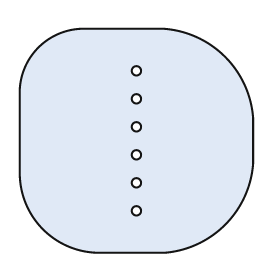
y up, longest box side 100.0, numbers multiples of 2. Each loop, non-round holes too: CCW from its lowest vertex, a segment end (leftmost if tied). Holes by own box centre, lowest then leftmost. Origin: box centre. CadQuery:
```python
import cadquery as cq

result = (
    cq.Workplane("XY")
    .moveTo(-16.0, -48.0)
    .lineTo(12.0, -48.0)
    .threePointArc((38.0, -36.0), (50.0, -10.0))
    .lineTo(50.0, 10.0)
    .threePointArc((38.0, 36.0), (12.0, 48.0))
    .lineTo(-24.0, 48.0)
    .threePointArc((-42.0, 40.0), (-50.0, 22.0))
    .lineTo(-50.0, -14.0)
    .threePointArc((-40.0, -38.0), (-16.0, -48.0))
    .close()
    .moveTo(0.0, -30.0)
    .circle(2.0)
    .moveTo(0.0, -18.0)
    .circle(2.0)
    .moveTo(0.0, -6.0)
    .circle(2.0)
    .moveTo(0.0, 6.0)
    .circle(2.0)
    .moveTo(0.0, 18.0)
    .circle(2.0)
    .moveTo(0.0, 30.0)
    .circle(2.0)
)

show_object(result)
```